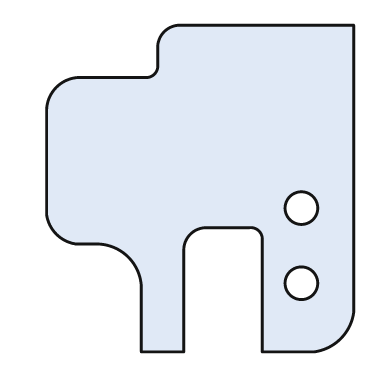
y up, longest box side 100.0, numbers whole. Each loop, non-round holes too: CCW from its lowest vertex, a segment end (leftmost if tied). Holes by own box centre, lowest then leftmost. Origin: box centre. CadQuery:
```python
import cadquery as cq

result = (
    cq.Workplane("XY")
    .moveTo(-18.0, -50.0)
    .lineTo(-5.0, -50.0)
    .lineTo(-5.0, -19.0)
    .threePointArc((-3.0, -14.0), (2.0, -12.0))
    .lineTo(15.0, -12.0)
    .threePointArc((18.0, -13.0), (19.0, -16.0))
    .lineTo(19.0, -50.0)
    .lineTo(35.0, -50.0)
    .threePointArc((43.0, -46.0), (47.0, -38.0))
    .lineTo(47.0, 50.0)
    .lineTo(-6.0, 50.0)
    .threePointArc((-11.0, 48.0), (-13.0, 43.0))
    .lineTo(-13.0, 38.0)
    .threePointArc((-14.0, 35.0), (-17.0, 34.0))
    .lineTo(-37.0, 34.0)
    .threePointArc((-44.0, 31.0), (-47.0, 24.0))
    .lineTo(-47.0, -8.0)
    .threePointArc((-44.0, -14.0), (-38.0, -17.0))
    .lineTo(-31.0, -17.0)
    .threePointArc((-22.0, -21.0), (-18.0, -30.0))
    .close()
    .moveTo(31.0, -29.0)
    .circle(5.0)
    .moveTo(31.0, -6.0)
    .circle(5.0)
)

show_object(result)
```